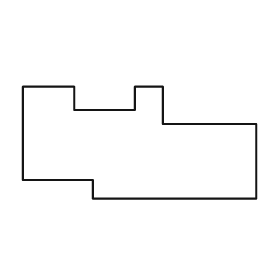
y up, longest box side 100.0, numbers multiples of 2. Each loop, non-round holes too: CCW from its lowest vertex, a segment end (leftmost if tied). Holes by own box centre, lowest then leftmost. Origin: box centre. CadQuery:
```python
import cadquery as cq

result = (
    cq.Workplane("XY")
    .moveTo(-20.0, -24.0)
    .lineTo(50.0, -24.0)
    .lineTo(50.0, 8.0)
    .lineTo(10.0, 8.0)
    .lineTo(10.0, 24.0)
    .lineTo(-2.0, 24.0)
    .lineTo(-2.0, 14.0)
    .lineTo(-28.0, 14.0)
    .lineTo(-28.0, 24.0)
    .lineTo(-50.0, 24.0)
    .lineTo(-50.0, -16.0)
    .lineTo(-20.0, -16.0)
    .close()
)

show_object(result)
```